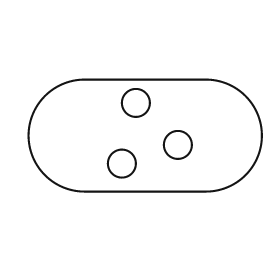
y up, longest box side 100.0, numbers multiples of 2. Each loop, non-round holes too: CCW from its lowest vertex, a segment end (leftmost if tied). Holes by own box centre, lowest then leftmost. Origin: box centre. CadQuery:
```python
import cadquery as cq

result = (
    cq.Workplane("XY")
    .moveTo(-26.0, -24.0)
    .lineTo(26.0, -24.0)
    .threePointArc((50.0, 0.0), (26.0, 24.0))
    .lineTo(-26.0, 24.0)
    .threePointArc((-50.0, 0.0), (-26.0, -24.0))
    .close()
    .moveTo(-10.0, -12.0)
    .circle(6.0)
    .moveTo(14.0, -4.0)
    .circle(6.0)
    .moveTo(-4.0, 14.0)
    .circle(6.0)
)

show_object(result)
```